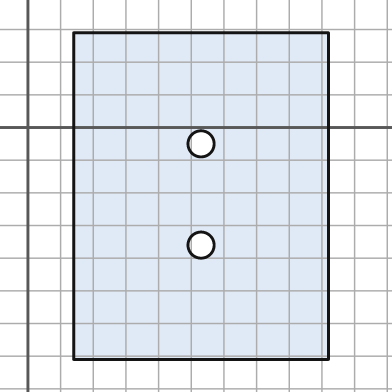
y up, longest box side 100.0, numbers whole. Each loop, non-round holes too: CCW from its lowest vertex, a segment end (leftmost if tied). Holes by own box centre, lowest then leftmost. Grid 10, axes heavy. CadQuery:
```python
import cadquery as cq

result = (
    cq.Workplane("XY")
    .moveTo(14.0, -71.0)
    .lineTo(92.0, -71.0)
    .lineTo(92.0, 29.0)
    .lineTo(14.0, 29.0)
    .close()
    .moveTo(53.0, -36.0)
    .circle(4.0)
    .moveTo(53.0, -5.0)
    .circle(4.0)
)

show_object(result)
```